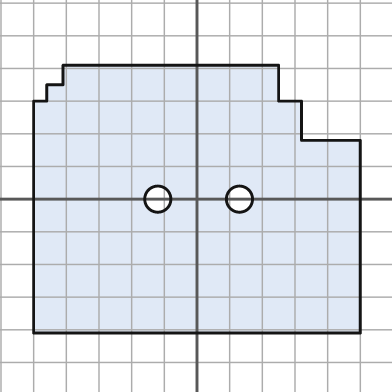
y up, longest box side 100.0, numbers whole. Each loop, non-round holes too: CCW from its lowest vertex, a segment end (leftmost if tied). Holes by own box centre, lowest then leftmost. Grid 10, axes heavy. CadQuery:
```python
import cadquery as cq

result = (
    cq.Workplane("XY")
    .moveTo(-50.0, -41.0)
    .lineTo(50.0, -41.0)
    .lineTo(50.0, 18.0)
    .lineTo(32.0, 18.0)
    .lineTo(32.0, 30.0)
    .lineTo(25.0, 30.0)
    .lineTo(25.0, 41.0)
    .lineTo(-41.0, 41.0)
    .lineTo(-41.0, 35.0)
    .lineTo(-46.0, 35.0)
    .lineTo(-46.0, 30.0)
    .lineTo(-50.0, 30.0)
    .close()
    .moveTo(-12.0, 0.0)
    .circle(4.0)
    .moveTo(13.0, 0.0)
    .circle(4.0)
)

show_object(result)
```